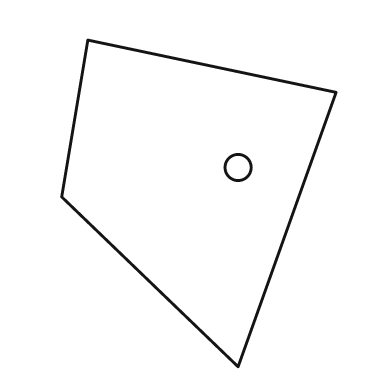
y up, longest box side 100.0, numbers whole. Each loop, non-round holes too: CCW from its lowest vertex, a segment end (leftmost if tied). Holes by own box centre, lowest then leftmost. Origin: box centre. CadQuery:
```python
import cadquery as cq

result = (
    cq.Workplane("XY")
    .moveTo(12.0, -50.0)
    .lineTo(42.0, 34.0)
    .lineTo(-34.0, 50.0)
    .lineTo(-42.0, 2.0)
    .close()
    .moveTo(12.0, 11.0)
    .circle(4.0)
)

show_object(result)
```